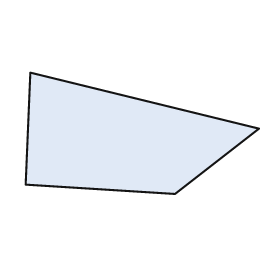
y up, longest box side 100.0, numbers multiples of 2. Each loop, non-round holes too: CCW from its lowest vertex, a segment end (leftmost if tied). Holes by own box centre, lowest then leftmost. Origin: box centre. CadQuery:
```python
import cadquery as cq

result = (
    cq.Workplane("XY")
    .moveTo(14.0, -26.0)
    .lineTo(50.0, 2.0)
    .lineTo(-48.0, 26.0)
    .lineTo(-50.0, -22.0)
    .close()
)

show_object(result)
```